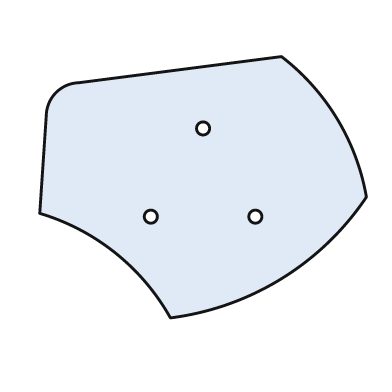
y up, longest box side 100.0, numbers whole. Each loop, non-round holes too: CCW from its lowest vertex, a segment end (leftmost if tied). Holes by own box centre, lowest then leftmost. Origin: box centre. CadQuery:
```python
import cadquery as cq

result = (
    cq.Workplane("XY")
    .moveTo(-10.0, -40.0)
    .threePointArc((24.0, -28.0), (50.0, -3.0))
    .threePointArc((41.0, 21.0), (24.0, 40.0))
    .lineTo(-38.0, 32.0)
    .threePointArc((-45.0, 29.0), (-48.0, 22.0))
    .lineTo(-50.0, -8.0)
    .threePointArc((-27.0, -20.0), (-10.0, -40.0))
    .close()
    .moveTo(-16.0, -9.0)
    .circle(2.0)
    .moveTo(16.0, -9.0)
    .circle(2.0)
    .moveTo(0.0, 18.0)
    .circle(2.0)
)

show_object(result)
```